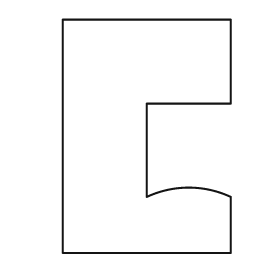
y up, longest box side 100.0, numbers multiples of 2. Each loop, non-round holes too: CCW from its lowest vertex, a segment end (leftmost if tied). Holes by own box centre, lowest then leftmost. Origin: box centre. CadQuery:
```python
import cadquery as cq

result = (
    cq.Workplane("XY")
    .moveTo(-36.0, -50.0)
    .lineTo(36.0, -50.0)
    .lineTo(36.0, -26.0)
    .threePointArc((18.0, -22.0), (0.0, -26.0))
    .lineTo(0.0, 14.0)
    .lineTo(36.0, 14.0)
    .lineTo(36.0, 50.0)
    .lineTo(-36.0, 50.0)
    .close()
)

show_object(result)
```